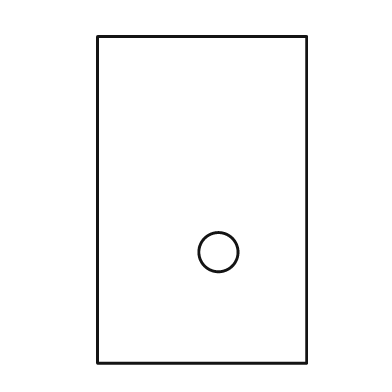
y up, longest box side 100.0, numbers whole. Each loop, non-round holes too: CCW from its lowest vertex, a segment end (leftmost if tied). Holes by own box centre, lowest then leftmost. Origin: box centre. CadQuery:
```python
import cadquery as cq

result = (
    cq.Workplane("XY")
    .moveTo(-32.0, -50.0)
    .lineTo(32.0, -50.0)
    .lineTo(32.0, 50.0)
    .lineTo(-32.0, 50.0)
    .close()
    .moveTo(5.0, -16.0)
    .circle(6.0)
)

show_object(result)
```